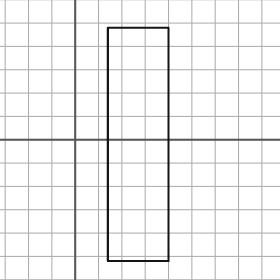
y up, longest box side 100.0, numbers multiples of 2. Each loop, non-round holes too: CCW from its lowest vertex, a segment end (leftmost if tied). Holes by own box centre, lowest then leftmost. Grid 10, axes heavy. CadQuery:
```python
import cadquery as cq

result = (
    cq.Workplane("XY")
    .moveTo(14.0, -52.0)
    .lineTo(40.0, -52.0)
    .lineTo(40.0, 48.0)
    .lineTo(14.0, 48.0)
    .close()
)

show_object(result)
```